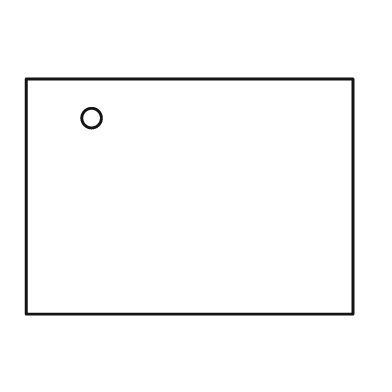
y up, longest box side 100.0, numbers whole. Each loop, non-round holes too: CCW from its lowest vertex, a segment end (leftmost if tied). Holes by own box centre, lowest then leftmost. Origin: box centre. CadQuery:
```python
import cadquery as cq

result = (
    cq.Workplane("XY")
    .moveTo(-50.0, -36.0)
    .lineTo(50.0, -36.0)
    .lineTo(50.0, 36.0)
    .lineTo(-50.0, 36.0)
    .close()
    .moveTo(-30.0, 24.0)
    .circle(3.0)
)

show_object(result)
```